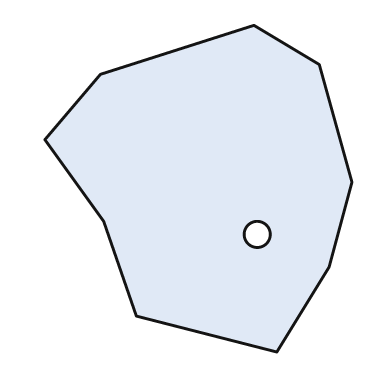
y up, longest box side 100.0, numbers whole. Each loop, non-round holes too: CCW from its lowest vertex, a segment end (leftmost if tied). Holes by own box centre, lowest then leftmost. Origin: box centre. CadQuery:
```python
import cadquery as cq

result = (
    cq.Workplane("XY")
    .moveTo(24.0, -50.0)
    .lineTo(40.0, -24.0)
    .lineTo(47.0, 2.0)
    .lineTo(37.0, 38.0)
    .lineTo(17.0, 50.0)
    .lineTo(-30.0, 35.0)
    .lineTo(-47.0, 15.0)
    .lineTo(-29.0, -10.0)
    .lineTo(-19.0, -39.0)
    .close()
    .moveTo(18.0, -14.0)
    .circle(4.0)
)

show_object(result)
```